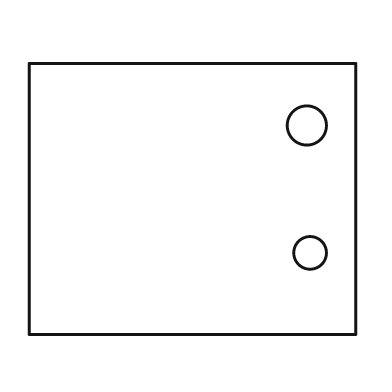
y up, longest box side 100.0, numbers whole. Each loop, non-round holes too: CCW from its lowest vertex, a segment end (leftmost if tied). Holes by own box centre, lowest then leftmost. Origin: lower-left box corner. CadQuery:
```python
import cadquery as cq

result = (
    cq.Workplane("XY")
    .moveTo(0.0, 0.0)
    .lineTo(100.0, 0.0)
    .lineTo(100.0, 83.0)
    .lineTo(0.0, 83.0)
    .close()
    .moveTo(86.0, 25.0)
    .circle(5.0)
    .moveTo(85.0, 64.0)
    .circle(6.0)
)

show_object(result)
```